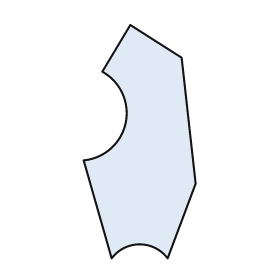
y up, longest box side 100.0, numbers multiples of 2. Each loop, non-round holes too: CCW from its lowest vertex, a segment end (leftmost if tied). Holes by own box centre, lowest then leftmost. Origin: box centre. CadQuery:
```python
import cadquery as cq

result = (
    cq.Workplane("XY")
    .moveTo(-12.0, -50.0)
    .threePointArc((0.0, -44.0), (12.0, -50.0))
    .lineTo(24.0, -18.0)
    .lineTo(18.0, 36.0)
    .lineTo(-4.0, 50.0)
    .lineTo(-16.0, 30.0)
    .threePointArc((-6.0, 8.0), (-24.0, -8.0))
    .close()
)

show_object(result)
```